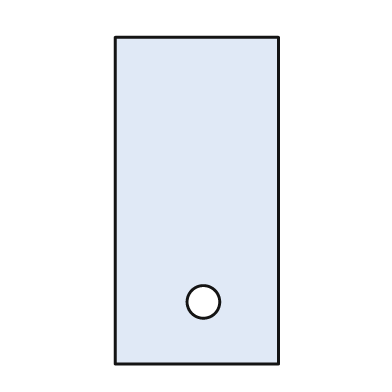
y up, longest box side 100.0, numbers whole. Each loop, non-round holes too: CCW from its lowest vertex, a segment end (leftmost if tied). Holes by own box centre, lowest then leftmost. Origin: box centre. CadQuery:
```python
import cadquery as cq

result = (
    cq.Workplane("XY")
    .moveTo(-25.0, -50.0)
    .lineTo(25.0, -50.0)
    .lineTo(25.0, 50.0)
    .lineTo(-25.0, 50.0)
    .close()
    .moveTo(2.0, -31.0)
    .circle(5.0)
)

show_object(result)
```